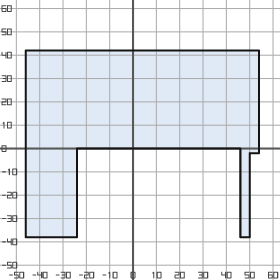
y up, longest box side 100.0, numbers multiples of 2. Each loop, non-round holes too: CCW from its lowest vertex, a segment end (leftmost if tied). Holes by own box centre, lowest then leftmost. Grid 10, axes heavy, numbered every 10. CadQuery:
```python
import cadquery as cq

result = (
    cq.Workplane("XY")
    .moveTo(-46.0, -38.0)
    .lineTo(-24.0, -38.0)
    .lineTo(-24.0, 0.0)
    .lineTo(46.0, 0.0)
    .lineTo(46.0, -38.0)
    .lineTo(50.0, -38.0)
    .lineTo(50.0, -2.0)
    .lineTo(54.0, -2.0)
    .lineTo(54.0, 42.0)
    .lineTo(-46.0, 42.0)
    .close()
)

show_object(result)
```